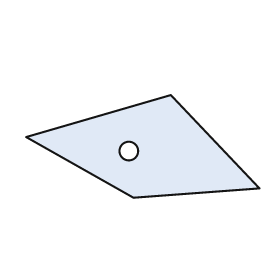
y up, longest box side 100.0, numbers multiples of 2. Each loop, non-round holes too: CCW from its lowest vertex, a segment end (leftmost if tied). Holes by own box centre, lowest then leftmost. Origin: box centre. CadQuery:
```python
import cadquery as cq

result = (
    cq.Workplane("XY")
    .moveTo(-4.0, -22.0)
    .lineTo(50.0, -18.0)
    .lineTo(12.0, 22.0)
    .lineTo(-50.0, 4.0)
    .close()
    .moveTo(-6.0, -2.0)
    .circle(4.0)
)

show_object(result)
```